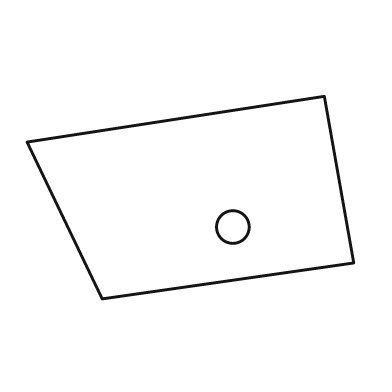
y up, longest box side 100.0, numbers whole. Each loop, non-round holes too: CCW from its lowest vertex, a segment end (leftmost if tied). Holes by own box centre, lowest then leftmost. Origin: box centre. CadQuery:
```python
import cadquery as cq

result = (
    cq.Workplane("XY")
    .moveTo(-27.0, -31.0)
    .lineTo(50.0, -20.0)
    .lineTo(41.0, 31.0)
    .lineTo(-50.0, 17.0)
    .close()
    .moveTo(13.0, -9.0)
    .circle(5.0)
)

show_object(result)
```